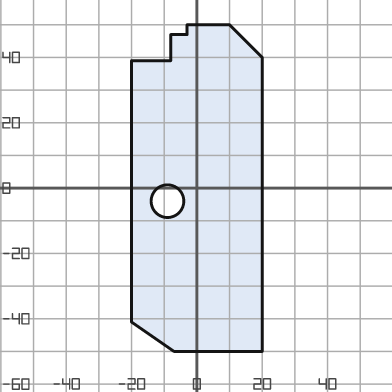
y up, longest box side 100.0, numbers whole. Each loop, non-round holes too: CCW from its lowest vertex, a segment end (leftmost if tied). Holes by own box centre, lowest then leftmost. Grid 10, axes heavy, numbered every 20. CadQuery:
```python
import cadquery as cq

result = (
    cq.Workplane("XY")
    .moveTo(-7.0, -50.0)
    .lineTo(20.0, -50.0)
    .lineTo(20.0, 40.0)
    .lineTo(10.0, 50.0)
    .lineTo(-3.0, 50.0)
    .lineTo(-3.0, 47.0)
    .lineTo(-8.0, 47.0)
    .lineTo(-8.0, 39.0)
    .lineTo(-20.0, 39.0)
    .lineTo(-20.0, -41.0)
    .close()
    .moveTo(-9.0, -4.0)
    .circle(5.0)
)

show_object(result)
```